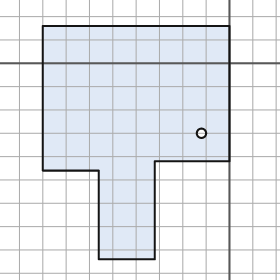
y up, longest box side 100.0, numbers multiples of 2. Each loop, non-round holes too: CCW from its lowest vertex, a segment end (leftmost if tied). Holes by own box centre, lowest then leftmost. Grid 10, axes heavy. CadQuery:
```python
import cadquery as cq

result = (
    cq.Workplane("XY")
    .moveTo(-56.0, -84.0)
    .lineTo(-32.0, -84.0)
    .lineTo(-32.0, -42.0)
    .lineTo(0.0, -42.0)
    .lineTo(0.0, 16.0)
    .lineTo(-80.0, 16.0)
    .lineTo(-80.0, -46.0)
    .lineTo(-56.0, -46.0)
    .close()
    .moveTo(-12.0, -30.0)
    .circle(2.0)
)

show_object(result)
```